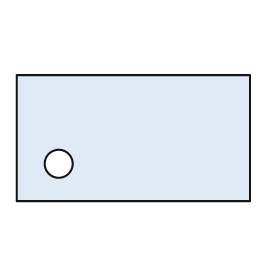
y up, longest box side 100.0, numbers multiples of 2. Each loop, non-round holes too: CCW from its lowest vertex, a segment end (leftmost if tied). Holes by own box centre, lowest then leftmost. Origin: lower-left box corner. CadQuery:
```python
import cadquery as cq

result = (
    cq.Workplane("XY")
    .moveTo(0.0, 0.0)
    .lineTo(100.0, 0.0)
    .lineTo(100.0, 54.0)
    .lineTo(0.0, 54.0)
    .close()
    .moveTo(18.0, 16.0)
    .circle(6.0)
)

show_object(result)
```